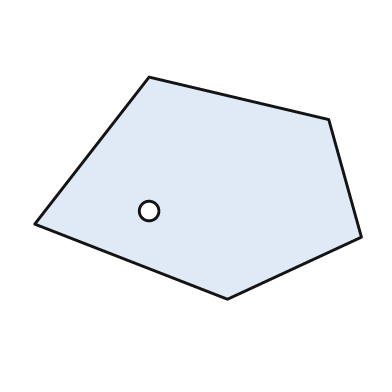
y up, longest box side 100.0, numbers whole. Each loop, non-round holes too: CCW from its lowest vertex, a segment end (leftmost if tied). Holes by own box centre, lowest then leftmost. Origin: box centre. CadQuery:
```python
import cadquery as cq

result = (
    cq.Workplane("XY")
    .moveTo(9.0, -34.0)
    .lineTo(50.0, -15.0)
    .lineTo(40.0, 21.0)
    .lineTo(-15.0, 34.0)
    .lineTo(-50.0, -11.0)
    .close()
    .moveTo(-15.0, -7.0)
    .circle(3.0)
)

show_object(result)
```